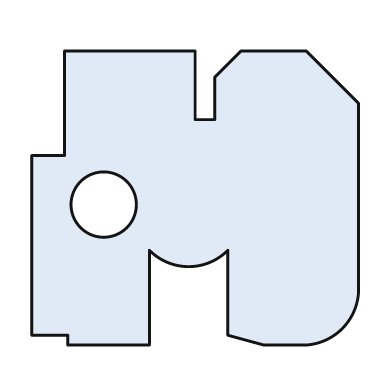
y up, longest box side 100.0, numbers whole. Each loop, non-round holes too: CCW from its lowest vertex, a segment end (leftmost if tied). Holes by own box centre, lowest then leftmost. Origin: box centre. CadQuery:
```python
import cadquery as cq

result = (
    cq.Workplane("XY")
    .moveTo(-39.0, -45.0)
    .lineTo(-14.0, -45.0)
    .lineTo(-14.0, -16.0)
    .threePointArc((-2.0, -21.0), (10.0, -16.0))
    .lineTo(10.0, -42.0)
    .lineTo(21.0, -45.0)
    .lineTo(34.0, -45.0)
    .threePointArc((45.0, -40.0), (50.0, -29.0))
    .lineTo(50.0, 29.0)
    .lineTo(34.0, 45.0)
    .lineTo(14.0, 45.0)
    .lineTo(6.0, 37.0)
    .lineTo(6.0, 24.0)
    .lineTo(0.0, 24.0)
    .lineTo(0.0, 45.0)
    .lineTo(-40.0, 45.0)
    .lineTo(-40.0, 13.0)
    .lineTo(-50.0, 13.0)
    .lineTo(-50.0, -42.0)
    .lineTo(-39.0, -42.0)
    .close()
    .moveTo(-28.0, -2.0)
    .circle(10.0)
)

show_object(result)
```